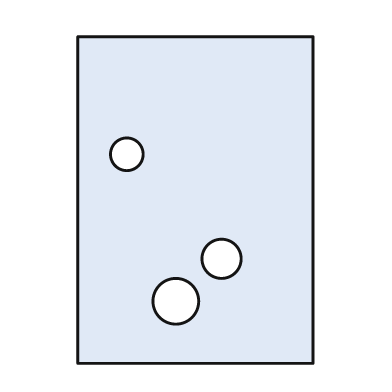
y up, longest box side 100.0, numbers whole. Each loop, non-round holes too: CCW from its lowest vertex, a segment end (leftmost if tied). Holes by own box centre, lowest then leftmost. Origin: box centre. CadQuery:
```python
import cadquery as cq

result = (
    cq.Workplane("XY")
    .moveTo(-36.0, -50.0)
    .lineTo(36.0, -50.0)
    .lineTo(36.0, 50.0)
    .lineTo(-36.0, 50.0)
    .close()
    .moveTo(-6.0, -31.0)
    .circle(7.0)
    .moveTo(8.0, -18.0)
    .circle(6.0)
    .moveTo(-21.0, 14.0)
    .circle(5.0)
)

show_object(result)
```